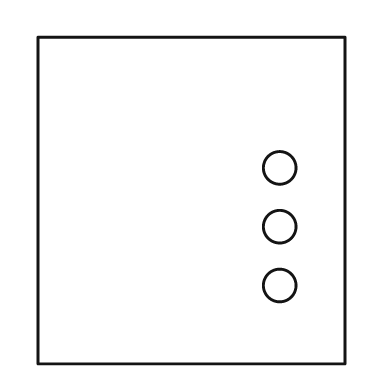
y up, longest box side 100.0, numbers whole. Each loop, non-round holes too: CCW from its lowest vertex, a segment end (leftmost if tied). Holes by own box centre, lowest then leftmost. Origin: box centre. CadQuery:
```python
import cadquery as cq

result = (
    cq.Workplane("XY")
    .moveTo(-47.0, -50.0)
    .lineTo(47.0, -50.0)
    .lineTo(47.0, 50.0)
    .lineTo(-47.0, 50.0)
    .close()
    .moveTo(27.0, -26.0)
    .circle(5.0)
    .moveTo(27.0, -8.0)
    .circle(5.0)
    .moveTo(27.0, 10.0)
    .circle(5.0)
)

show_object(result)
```